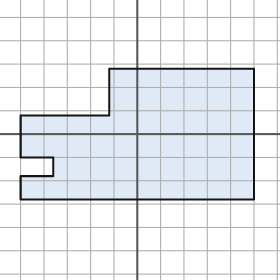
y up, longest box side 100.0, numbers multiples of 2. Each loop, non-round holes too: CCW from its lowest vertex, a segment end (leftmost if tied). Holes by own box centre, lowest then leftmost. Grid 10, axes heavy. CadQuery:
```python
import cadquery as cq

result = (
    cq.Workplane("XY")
    .moveTo(-50.0, -28.0)
    .lineTo(50.0, -28.0)
    .lineTo(50.0, 28.0)
    .lineTo(-12.0, 28.0)
    .lineTo(-12.0, 8.0)
    .lineTo(-50.0, 8.0)
    .lineTo(-50.0, -10.0)
    .lineTo(-36.0, -10.0)
    .lineTo(-36.0, -18.0)
    .lineTo(-50.0, -18.0)
    .close()
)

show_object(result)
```